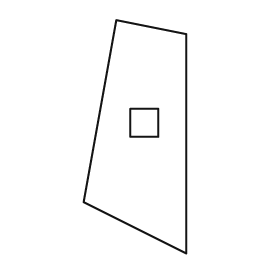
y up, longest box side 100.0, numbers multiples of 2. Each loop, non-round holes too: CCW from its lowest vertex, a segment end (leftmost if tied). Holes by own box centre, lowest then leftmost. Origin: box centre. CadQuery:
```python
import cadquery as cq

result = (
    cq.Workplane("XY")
    .moveTo(22.0, -50.0)
    .lineTo(22.0, 44.0)
    .lineTo(-8.0, 50.0)
    .lineTo(-22.0, -28.0)
    .close()
    .moveTo(-2.0, 0.0)
    .lineTo(10.0, 0.0)
    .lineTo(10.0, 12.0)
    .lineTo(-2.0, 12.0)
    .close()
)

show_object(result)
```